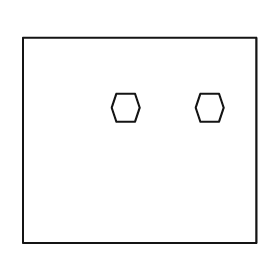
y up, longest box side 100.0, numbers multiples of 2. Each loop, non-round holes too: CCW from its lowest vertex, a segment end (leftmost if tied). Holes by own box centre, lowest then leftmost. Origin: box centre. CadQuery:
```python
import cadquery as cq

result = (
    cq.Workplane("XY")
    .moveTo(-50.0, -44.0)
    .lineTo(50.0, -44.0)
    .lineTo(50.0, 44.0)
    .lineTo(-50.0, 44.0)
    .close()
    .moveTo(-10.0, 8.0)
    .lineTo(-2.0, 8.0)
    .lineTo(0.0, 14.0)
    .lineTo(-2.0, 20.0)
    .lineTo(-10.0, 20.0)
    .lineTo(-12.0, 14.0)
    .close()
    .moveTo(26.0, 8.0)
    .lineTo(34.0, 8.0)
    .lineTo(36.0, 14.0)
    .lineTo(34.0, 20.0)
    .lineTo(26.0, 20.0)
    .lineTo(24.0, 14.0)
    .close()
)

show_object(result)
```